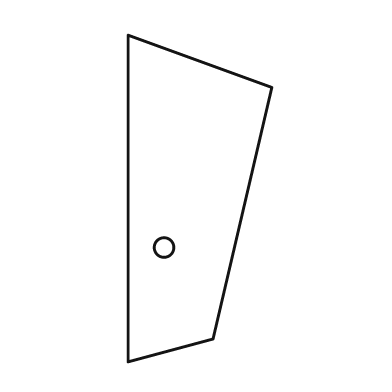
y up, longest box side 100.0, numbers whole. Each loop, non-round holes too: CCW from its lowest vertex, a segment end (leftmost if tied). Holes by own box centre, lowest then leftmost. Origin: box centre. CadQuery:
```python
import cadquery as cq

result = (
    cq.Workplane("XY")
    .moveTo(-22.0, -50.0)
    .lineTo(4.0, -43.0)
    .lineTo(22.0, 34.0)
    .lineTo(-22.0, 50.0)
    .close()
    .moveTo(-11.0, -15.0)
    .circle(3.0)
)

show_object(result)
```